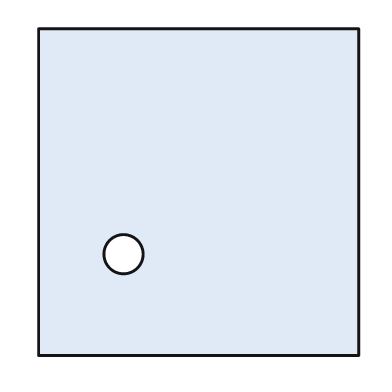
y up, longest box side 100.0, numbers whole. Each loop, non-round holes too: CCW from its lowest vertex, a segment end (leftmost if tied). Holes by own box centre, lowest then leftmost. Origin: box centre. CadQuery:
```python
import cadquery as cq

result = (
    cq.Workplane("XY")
    .moveTo(-49.0, -50.0)
    .lineTo(49.0, -50.0)
    .lineTo(49.0, 50.0)
    .lineTo(-49.0, 50.0)
    .close()
    .moveTo(-23.0, -19.0)
    .circle(6.0)
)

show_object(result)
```